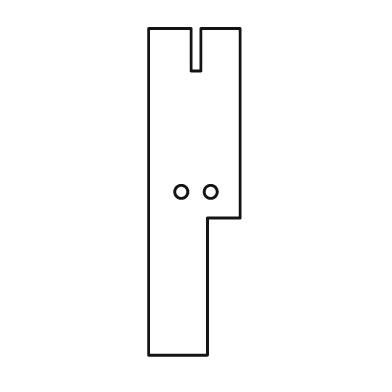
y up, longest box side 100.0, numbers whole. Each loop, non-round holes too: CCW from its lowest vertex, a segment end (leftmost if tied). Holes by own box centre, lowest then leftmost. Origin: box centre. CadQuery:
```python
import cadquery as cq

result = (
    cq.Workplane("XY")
    .moveTo(-14.0, -50.0)
    .lineTo(4.0, -50.0)
    .lineTo(4.0, -8.0)
    .lineTo(14.0, -8.0)
    .lineTo(14.0, 50.0)
    .lineTo(2.0, 50.0)
    .lineTo(2.0, 37.0)
    .lineTo(-1.0, 37.0)
    .lineTo(-1.0, 50.0)
    .lineTo(-14.0, 50.0)
    .close()
    .moveTo(-4.0, 0.0)
    .circle(2.0)
    .moveTo(5.0, 0.0)
    .circle(2.0)
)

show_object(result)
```